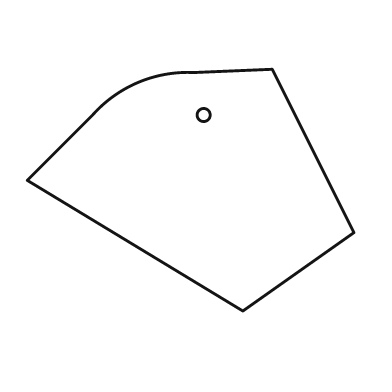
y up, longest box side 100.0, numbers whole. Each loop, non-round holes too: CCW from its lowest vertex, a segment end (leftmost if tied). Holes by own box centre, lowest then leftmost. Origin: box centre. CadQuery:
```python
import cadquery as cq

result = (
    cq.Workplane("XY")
    .moveTo(16.0, -37.0)
    .lineTo(50.0, -13.0)
    .lineTo(25.0, 37.0)
    .lineTo(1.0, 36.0)
    .threePointArc((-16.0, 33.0), (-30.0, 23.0))
    .lineTo(-50.0, 3.0)
    .close()
    .moveTo(4.0, 23.0)
    .circle(2.0)
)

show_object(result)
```